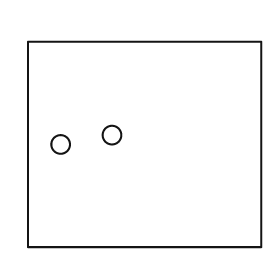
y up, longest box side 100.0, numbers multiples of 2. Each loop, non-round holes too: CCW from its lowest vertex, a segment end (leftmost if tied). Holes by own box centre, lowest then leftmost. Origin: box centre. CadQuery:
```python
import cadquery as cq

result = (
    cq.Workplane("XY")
    .moveTo(-50.0, -44.0)
    .lineTo(50.0, -44.0)
    .lineTo(50.0, 44.0)
    .lineTo(-50.0, 44.0)
    .close()
    .moveTo(-36.0, 0.0)
    .circle(4.0)
    .moveTo(-14.0, 4.0)
    .circle(4.0)
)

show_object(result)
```